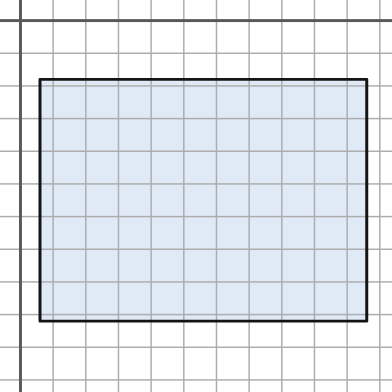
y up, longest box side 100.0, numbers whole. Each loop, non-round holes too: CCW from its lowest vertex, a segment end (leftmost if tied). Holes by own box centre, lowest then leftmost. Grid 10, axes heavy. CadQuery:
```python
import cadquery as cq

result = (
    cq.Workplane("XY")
    .moveTo(6.0, -92.0)
    .lineTo(106.0, -92.0)
    .lineTo(106.0, -18.0)
    .lineTo(6.0, -18.0)
    .close()
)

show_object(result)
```